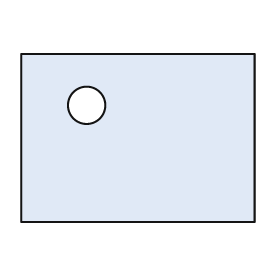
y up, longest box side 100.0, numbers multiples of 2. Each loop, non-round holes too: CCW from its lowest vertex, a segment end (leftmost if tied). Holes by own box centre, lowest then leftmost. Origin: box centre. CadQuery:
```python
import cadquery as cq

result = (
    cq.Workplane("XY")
    .moveTo(-50.0, -36.0)
    .lineTo(50.0, -36.0)
    .lineTo(50.0, 36.0)
    .lineTo(-50.0, 36.0)
    .close()
    .moveTo(-22.0, 14.0)
    .circle(8.0)
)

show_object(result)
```